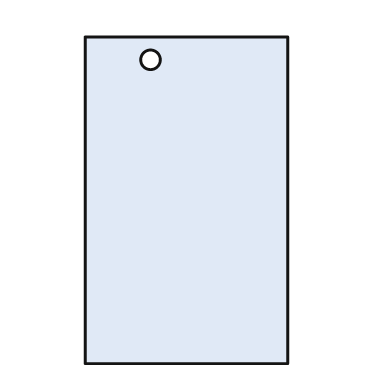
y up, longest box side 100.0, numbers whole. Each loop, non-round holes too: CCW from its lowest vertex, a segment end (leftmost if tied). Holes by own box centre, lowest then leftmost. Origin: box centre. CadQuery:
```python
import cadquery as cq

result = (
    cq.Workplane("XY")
    .moveTo(-31.0, -50.0)
    .lineTo(31.0, -50.0)
    .lineTo(31.0, 50.0)
    .lineTo(-31.0, 50.0)
    .close()
    .moveTo(-11.0, 43.0)
    .circle(3.0)
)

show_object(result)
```